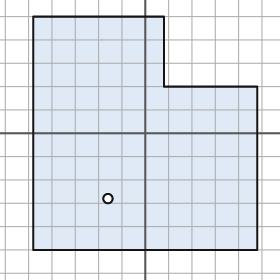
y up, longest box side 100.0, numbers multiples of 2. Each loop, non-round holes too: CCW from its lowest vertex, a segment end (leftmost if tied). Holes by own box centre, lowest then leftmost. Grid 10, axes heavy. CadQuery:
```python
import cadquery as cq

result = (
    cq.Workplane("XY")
    .moveTo(-48.0, -50.0)
    .lineTo(48.0, -50.0)
    .lineTo(48.0, 20.0)
    .lineTo(8.0, 20.0)
    .lineTo(8.0, 50.0)
    .lineTo(-48.0, 50.0)
    .close()
    .moveTo(-16.0, -28.0)
    .circle(2.0)
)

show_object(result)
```